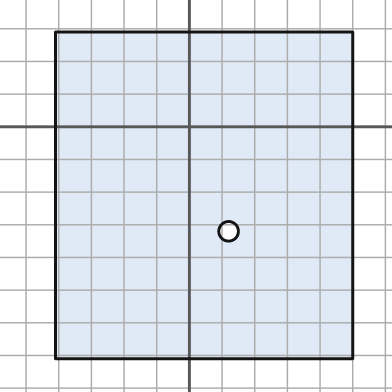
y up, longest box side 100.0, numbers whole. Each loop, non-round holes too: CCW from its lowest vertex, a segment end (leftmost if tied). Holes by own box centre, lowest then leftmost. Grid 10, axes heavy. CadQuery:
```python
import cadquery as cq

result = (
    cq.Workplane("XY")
    .moveTo(-41.0, -71.0)
    .lineTo(50.0, -71.0)
    .lineTo(50.0, 29.0)
    .lineTo(-41.0, 29.0)
    .close()
    .moveTo(12.0, -32.0)
    .circle(3.0)
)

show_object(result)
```